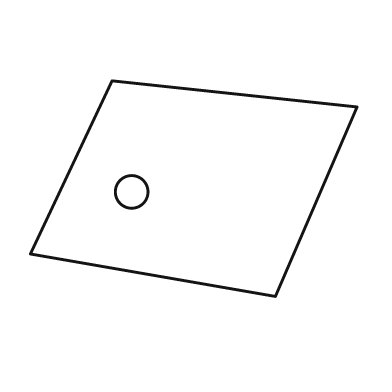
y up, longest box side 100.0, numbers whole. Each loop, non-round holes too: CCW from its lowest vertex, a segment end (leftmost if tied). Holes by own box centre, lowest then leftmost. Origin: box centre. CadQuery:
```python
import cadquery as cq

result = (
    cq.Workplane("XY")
    .moveTo(25.0, -33.0)
    .lineTo(50.0, 25.0)
    .lineTo(-25.0, 33.0)
    .lineTo(-50.0, -20.0)
    .close()
    .moveTo(-19.0, -1.0)
    .circle(5.0)
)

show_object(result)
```